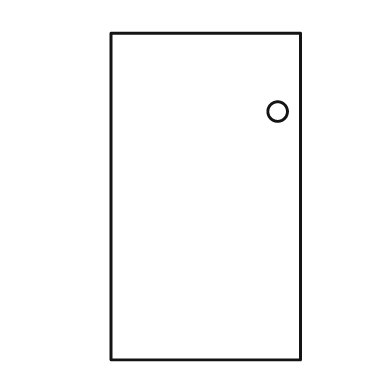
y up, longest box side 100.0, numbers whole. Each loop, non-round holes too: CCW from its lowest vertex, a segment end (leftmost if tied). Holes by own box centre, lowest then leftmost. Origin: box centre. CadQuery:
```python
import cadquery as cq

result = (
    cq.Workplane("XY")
    .moveTo(-29.0, -50.0)
    .lineTo(29.0, -50.0)
    .lineTo(29.0, 50.0)
    .lineTo(-29.0, 50.0)
    .close()
    .moveTo(22.0, 26.0)
    .circle(3.0)
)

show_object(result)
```